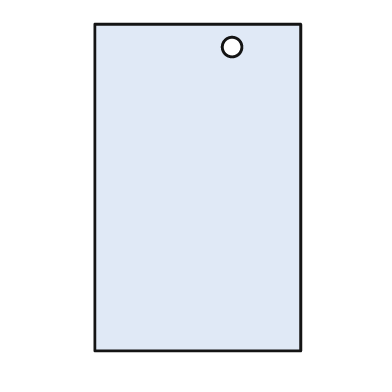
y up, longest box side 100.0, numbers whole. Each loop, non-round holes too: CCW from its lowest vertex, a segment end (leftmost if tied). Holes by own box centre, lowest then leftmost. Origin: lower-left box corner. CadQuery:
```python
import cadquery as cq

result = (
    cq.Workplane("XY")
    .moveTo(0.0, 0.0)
    .lineTo(63.0, 0.0)
    .lineTo(63.0, 100.0)
    .lineTo(0.0, 100.0)
    .close()
    .moveTo(42.0, 93.0)
    .circle(3.0)
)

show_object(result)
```